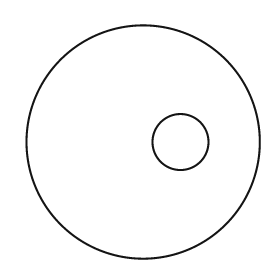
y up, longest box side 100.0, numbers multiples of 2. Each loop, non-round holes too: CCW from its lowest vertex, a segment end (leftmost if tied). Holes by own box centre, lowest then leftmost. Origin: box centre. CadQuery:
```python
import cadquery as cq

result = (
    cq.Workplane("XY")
    .moveTo(0.0, 0.0)
    .circle(50.0)
    .moveTo(16.0, 0.0)
    .circle(12.0)
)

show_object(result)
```